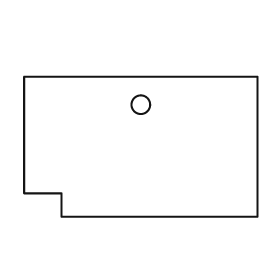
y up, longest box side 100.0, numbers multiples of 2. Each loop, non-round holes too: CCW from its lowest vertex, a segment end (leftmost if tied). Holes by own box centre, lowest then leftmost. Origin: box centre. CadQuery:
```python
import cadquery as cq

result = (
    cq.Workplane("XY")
    .moveTo(-34.0, -30.0)
    .lineTo(50.0, -30.0)
    .lineTo(50.0, 30.0)
    .lineTo(-50.0, 30.0)
    .lineTo(-50.0, -20.0)
    .lineTo(-34.0, -20.0)
    .close()
    .moveTo(0.0, 18.0)
    .circle(4.0)
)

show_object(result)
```